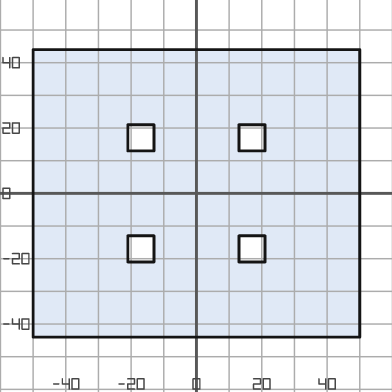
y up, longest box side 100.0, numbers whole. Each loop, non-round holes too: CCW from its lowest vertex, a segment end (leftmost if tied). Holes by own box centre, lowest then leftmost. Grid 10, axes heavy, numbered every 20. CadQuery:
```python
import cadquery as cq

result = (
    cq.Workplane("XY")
    .moveTo(-50.0, -44.0)
    .lineTo(50.0, -44.0)
    .lineTo(50.0, 44.0)
    .lineTo(-50.0, 44.0)
    .close()
    .moveTo(-21.0, -21.0)
    .lineTo(-13.0, -21.0)
    .lineTo(-13.0, -13.0)
    .lineTo(-21.0, -13.0)
    .close()
    .moveTo(13.0, -21.0)
    .lineTo(21.0, -21.0)
    .lineTo(21.0, -13.0)
    .lineTo(13.0, -13.0)
    .close()
    .moveTo(-21.0, 13.0)
    .lineTo(-13.0, 13.0)
    .lineTo(-13.0, 21.0)
    .lineTo(-21.0, 21.0)
    .close()
    .moveTo(13.0, 13.0)
    .lineTo(21.0, 13.0)
    .lineTo(21.0, 21.0)
    .lineTo(13.0, 21.0)
    .close()
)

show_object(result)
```